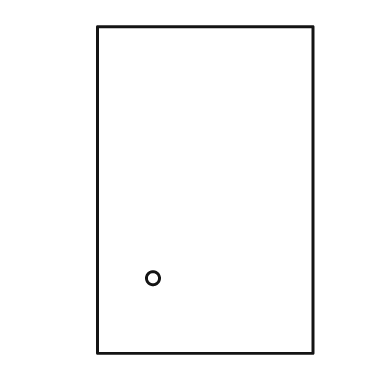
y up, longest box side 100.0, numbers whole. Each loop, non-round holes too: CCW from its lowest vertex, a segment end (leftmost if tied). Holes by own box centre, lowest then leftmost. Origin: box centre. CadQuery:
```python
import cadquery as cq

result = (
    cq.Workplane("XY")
    .moveTo(-33.0, -50.0)
    .lineTo(33.0, -50.0)
    .lineTo(33.0, 50.0)
    .lineTo(-33.0, 50.0)
    .close()
    .moveTo(-16.0, -27.0)
    .circle(2.0)
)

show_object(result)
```